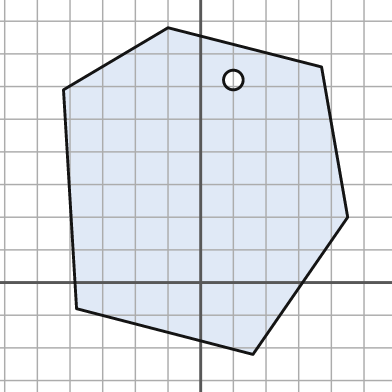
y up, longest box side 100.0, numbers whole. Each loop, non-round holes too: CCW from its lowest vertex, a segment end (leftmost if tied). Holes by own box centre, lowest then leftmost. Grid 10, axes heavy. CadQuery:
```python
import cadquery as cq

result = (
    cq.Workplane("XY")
    .moveTo(16.0, -22.0)
    .lineTo(45.0, 20.0)
    .lineTo(37.0, 66.0)
    .lineTo(-10.0, 78.0)
    .lineTo(-42.0, 59.0)
    .lineTo(-38.0, -8.0)
    .close()
    .moveTo(10.0, 62.0)
    .circle(3.0)
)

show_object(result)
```